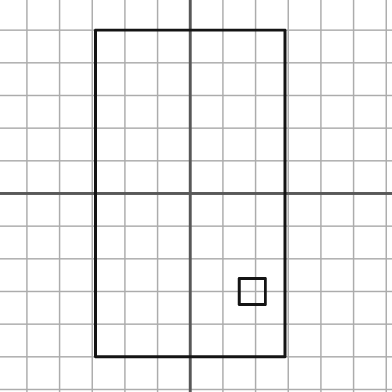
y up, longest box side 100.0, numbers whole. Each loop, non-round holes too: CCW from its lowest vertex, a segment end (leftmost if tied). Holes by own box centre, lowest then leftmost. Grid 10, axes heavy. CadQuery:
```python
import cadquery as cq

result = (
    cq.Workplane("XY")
    .moveTo(-29.0, -50.0)
    .lineTo(29.0, -50.0)
    .lineTo(29.0, 50.0)
    .lineTo(-29.0, 50.0)
    .close()
    .moveTo(15.0, -34.0)
    .lineTo(23.0, -34.0)
    .lineTo(23.0, -26.0)
    .lineTo(15.0, -26.0)
    .close()
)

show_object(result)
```